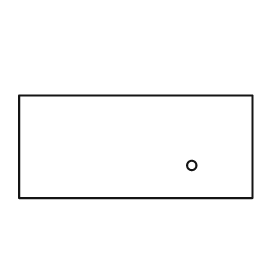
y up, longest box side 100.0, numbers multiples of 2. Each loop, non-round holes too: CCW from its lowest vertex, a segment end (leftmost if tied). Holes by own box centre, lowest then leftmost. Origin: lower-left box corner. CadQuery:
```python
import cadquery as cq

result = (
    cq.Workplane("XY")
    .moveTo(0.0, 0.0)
    .lineTo(100.0, 0.0)
    .lineTo(100.0, 44.0)
    .lineTo(0.0, 44.0)
    .close()
    .moveTo(74.0, 14.0)
    .circle(2.0)
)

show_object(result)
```